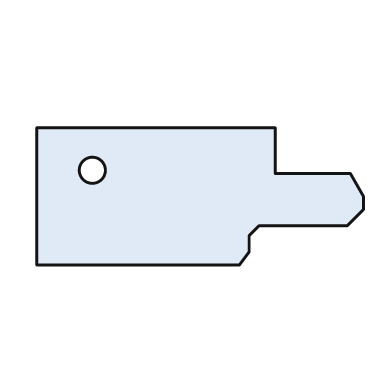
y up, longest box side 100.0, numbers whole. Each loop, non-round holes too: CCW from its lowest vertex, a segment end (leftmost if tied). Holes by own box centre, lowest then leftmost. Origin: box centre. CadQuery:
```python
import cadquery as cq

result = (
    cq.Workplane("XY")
    .moveTo(-50.0, -21.0)
    .lineTo(12.0, -21.0)
    .lineTo(15.0, -17.0)
    .lineTo(15.0, -12.0)
    .lineTo(18.0, -9.0)
    .lineTo(45.0, -9.0)
    .lineTo(50.0, -4.0)
    .lineTo(50.0, 0.0)
    .lineTo(46.0, 7.0)
    .lineTo(23.0, 7.0)
    .lineTo(23.0, 21.0)
    .lineTo(-50.0, 21.0)
    .close()
    .moveTo(-33.0, 8.0)
    .circle(4.0)
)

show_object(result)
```